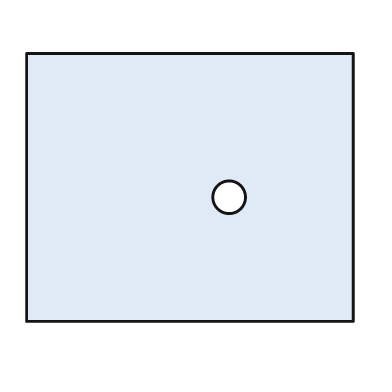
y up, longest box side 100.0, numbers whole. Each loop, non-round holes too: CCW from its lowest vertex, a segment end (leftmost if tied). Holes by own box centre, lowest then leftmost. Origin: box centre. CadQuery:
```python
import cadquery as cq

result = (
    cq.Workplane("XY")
    .moveTo(-50.0, -41.0)
    .lineTo(50.0, -41.0)
    .lineTo(50.0, 41.0)
    .lineTo(-50.0, 41.0)
    .close()
    .moveTo(12.0, -3.0)
    .circle(5.0)
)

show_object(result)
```